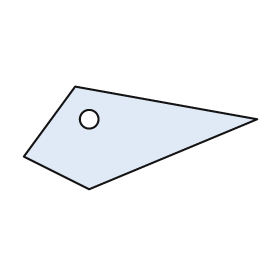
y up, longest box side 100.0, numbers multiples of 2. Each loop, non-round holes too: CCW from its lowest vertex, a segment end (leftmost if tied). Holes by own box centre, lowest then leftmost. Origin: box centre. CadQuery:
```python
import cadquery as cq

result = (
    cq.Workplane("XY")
    .moveTo(-22.0, -22.0)
    .lineTo(50.0, 8.0)
    .lineTo(-28.0, 22.0)
    .lineTo(-50.0, -8.0)
    .close()
    .moveTo(-22.0, 8.0)
    .circle(4.0)
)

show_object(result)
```